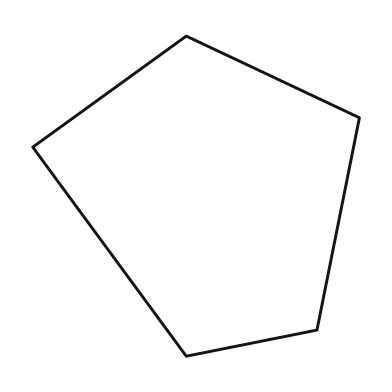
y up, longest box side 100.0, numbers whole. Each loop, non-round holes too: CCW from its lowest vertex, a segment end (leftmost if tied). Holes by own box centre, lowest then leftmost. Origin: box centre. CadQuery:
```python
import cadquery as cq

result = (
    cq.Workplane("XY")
    .moveTo(-3.0, -49.0)
    .lineTo(37.0, -41.0)
    .lineTo(50.0, 24.0)
    .lineTo(-3.0, 49.0)
    .lineTo(-50.0, 15.0)
    .close()
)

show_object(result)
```